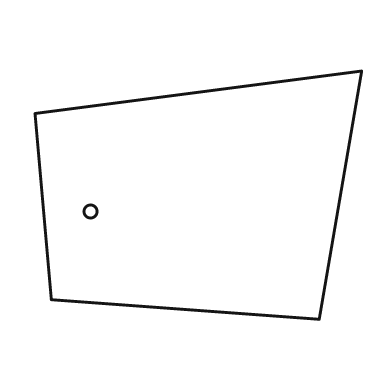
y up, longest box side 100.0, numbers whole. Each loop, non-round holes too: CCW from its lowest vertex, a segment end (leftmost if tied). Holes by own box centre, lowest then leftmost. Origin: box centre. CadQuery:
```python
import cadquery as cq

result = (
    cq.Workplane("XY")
    .moveTo(37.0, -38.0)
    .lineTo(50.0, 38.0)
    .lineTo(-50.0, 25.0)
    .lineTo(-45.0, -32.0)
    .close()
    .moveTo(-33.0, -5.0)
    .circle(2.0)
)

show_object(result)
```